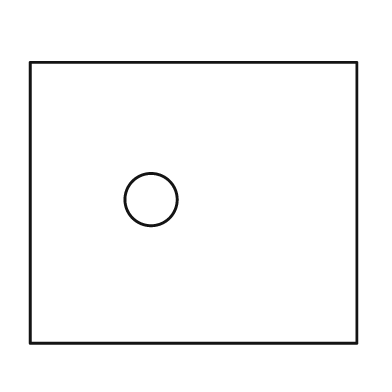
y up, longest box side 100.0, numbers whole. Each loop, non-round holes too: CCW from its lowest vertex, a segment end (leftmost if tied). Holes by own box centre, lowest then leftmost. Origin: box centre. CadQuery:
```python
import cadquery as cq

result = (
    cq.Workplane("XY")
    .moveTo(-50.0, -43.0)
    .lineTo(50.0, -43.0)
    .lineTo(50.0, 43.0)
    .lineTo(-50.0, 43.0)
    .close()
    .moveTo(-13.0, 1.0)
    .circle(8.0)
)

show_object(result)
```